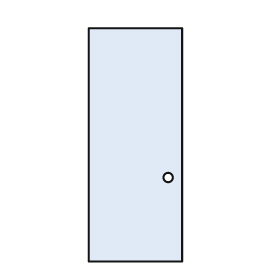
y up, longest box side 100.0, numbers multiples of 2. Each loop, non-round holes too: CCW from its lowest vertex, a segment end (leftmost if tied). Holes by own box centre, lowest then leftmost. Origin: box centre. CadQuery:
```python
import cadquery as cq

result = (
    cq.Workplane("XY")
    .moveTo(-20.0, -50.0)
    .lineTo(20.0, -50.0)
    .lineTo(20.0, 50.0)
    .lineTo(-20.0, 50.0)
    .close()
    .moveTo(14.0, -14.0)
    .circle(2.0)
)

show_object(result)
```